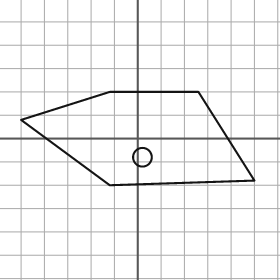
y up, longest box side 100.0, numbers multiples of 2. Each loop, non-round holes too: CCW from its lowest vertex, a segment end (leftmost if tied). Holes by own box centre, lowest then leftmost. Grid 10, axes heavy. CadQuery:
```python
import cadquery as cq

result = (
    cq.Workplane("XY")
    .moveTo(-12.0, -20.0)
    .lineTo(50.0, -18.0)
    .lineTo(26.0, 20.0)
    .lineTo(-12.0, 20.0)
    .lineTo(-50.0, 8.0)
    .close()
    .moveTo(2.0, -8.0)
    .circle(4.0)
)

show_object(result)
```